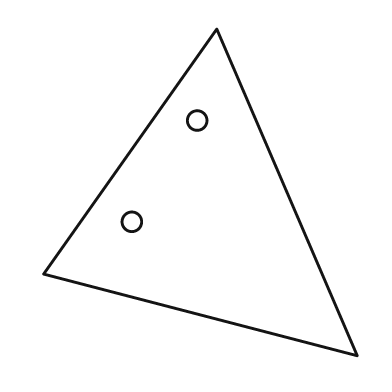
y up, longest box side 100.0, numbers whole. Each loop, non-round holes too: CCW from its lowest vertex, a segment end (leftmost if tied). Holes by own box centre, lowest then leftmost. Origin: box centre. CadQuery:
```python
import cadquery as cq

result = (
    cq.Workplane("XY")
    .moveTo(48.0, -50.0)
    .lineTo(5.0, 50.0)
    .lineTo(-48.0, -25.0)
    .close()
    .moveTo(-21.0, -9.0)
    .circle(3.0)
    .moveTo(-1.0, 22.0)
    .circle(3.0)
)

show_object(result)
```